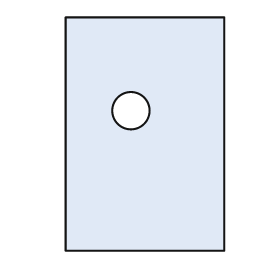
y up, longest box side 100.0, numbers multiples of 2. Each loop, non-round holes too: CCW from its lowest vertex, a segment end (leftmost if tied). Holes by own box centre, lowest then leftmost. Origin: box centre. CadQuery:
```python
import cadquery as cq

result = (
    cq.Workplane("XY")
    .moveTo(-34.0, -50.0)
    .lineTo(34.0, -50.0)
    .lineTo(34.0, 50.0)
    .lineTo(-34.0, 50.0)
    .close()
    .moveTo(-6.0, 10.0)
    .circle(8.0)
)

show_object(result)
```